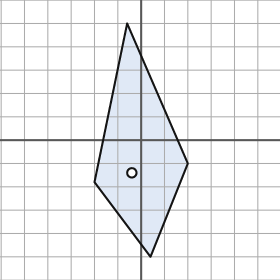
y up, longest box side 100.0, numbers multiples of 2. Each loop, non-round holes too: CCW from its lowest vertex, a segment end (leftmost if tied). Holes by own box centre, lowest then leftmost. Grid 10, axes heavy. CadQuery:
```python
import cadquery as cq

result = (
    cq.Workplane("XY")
    .moveTo(4.0, -50.0)
    .lineTo(20.0, -10.0)
    .lineTo(-6.0, 50.0)
    .lineTo(-20.0, -18.0)
    .close()
    .moveTo(-4.0, -14.0)
    .circle(2.0)
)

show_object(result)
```